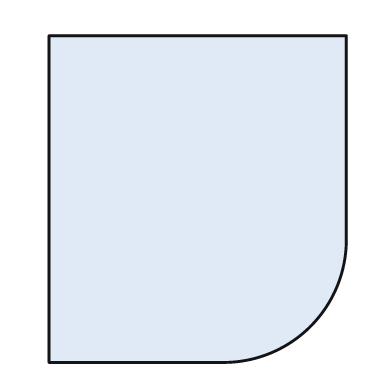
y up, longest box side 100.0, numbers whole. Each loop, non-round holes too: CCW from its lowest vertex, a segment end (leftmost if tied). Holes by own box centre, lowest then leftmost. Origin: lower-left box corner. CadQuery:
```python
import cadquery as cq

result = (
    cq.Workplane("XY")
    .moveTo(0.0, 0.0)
    .lineTo(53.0, 0.0)
    .threePointArc((80.0, 11.0), (91.0, 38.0))
    .lineTo(91.0, 100.0)
    .lineTo(0.0, 100.0)
    .close()
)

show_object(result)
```